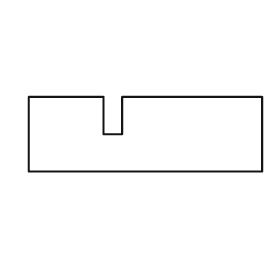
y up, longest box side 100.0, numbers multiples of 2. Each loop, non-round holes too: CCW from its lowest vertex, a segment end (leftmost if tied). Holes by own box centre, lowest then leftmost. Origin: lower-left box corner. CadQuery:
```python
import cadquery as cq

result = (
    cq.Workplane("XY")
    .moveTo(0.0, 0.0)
    .lineTo(100.0, 0.0)
    .lineTo(100.0, 32.0)
    .lineTo(40.0, 32.0)
    .lineTo(40.0, 16.0)
    .lineTo(32.0, 16.0)
    .lineTo(32.0, 32.0)
    .lineTo(0.0, 32.0)
    .close()
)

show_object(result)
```